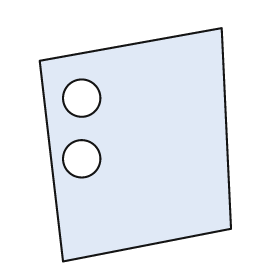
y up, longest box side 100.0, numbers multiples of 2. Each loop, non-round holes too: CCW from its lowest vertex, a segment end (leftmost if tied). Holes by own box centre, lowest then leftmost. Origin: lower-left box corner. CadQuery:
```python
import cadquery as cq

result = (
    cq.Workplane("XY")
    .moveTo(10.0, 0.0)
    .lineTo(82.0, 14.0)
    .lineTo(78.0, 100.0)
    .lineTo(0.0, 86.0)
    .close()
    .moveTo(18.0, 44.0)
    .circle(8.0)
    .moveTo(18.0, 70.0)
    .circle(8.0)
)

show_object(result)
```